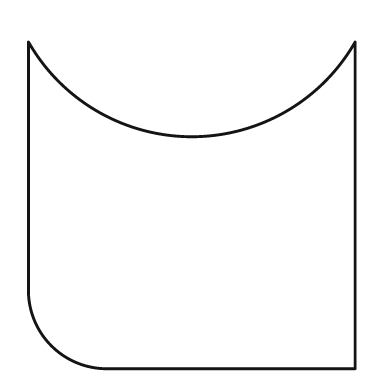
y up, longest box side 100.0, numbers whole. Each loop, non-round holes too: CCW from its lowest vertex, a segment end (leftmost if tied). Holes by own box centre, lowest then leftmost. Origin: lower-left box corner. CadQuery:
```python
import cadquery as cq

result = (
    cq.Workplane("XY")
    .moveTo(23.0, 0.0)
    .lineTo(100.0, 0.0)
    .lineTo(100.0, 100.0)
    .threePointArc((50.0, 71.0), (0.0, 100.0))
    .lineTo(0.0, 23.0)
    .threePointArc((7.0, 7.0), (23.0, 0.0))
    .close()
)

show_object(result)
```